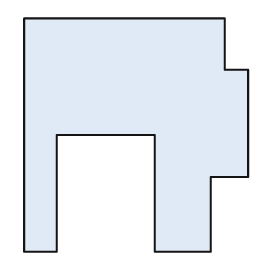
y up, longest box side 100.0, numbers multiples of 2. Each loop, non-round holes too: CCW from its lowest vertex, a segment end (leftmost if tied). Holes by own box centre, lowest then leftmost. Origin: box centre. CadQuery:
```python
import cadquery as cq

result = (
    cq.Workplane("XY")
    .moveTo(-48.0, -50.0)
    .lineTo(-34.0, -50.0)
    .lineTo(-34.0, 0.0)
    .lineTo(8.0, 0.0)
    .lineTo(8.0, -50.0)
    .lineTo(32.0, -50.0)
    .lineTo(32.0, -18.0)
    .lineTo(48.0, -18.0)
    .lineTo(48.0, 28.0)
    .lineTo(38.0, 28.0)
    .lineTo(38.0, 50.0)
    .lineTo(-48.0, 50.0)
    .close()
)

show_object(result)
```